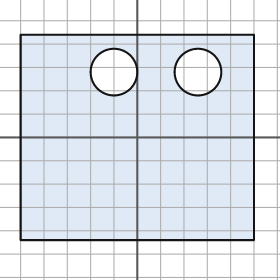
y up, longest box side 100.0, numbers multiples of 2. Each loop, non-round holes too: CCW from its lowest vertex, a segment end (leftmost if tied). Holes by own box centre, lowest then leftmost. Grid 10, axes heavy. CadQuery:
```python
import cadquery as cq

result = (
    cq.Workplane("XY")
    .moveTo(-50.0, -44.0)
    .lineTo(50.0, -44.0)
    .lineTo(50.0, 44.0)
    .lineTo(-50.0, 44.0)
    .close()
    .moveTo(-10.0, 28.0)
    .circle(10.0)
    .moveTo(26.0, 28.0)
    .circle(10.0)
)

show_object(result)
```